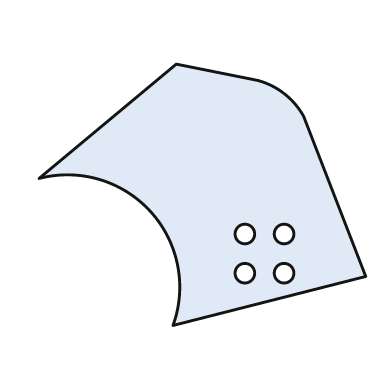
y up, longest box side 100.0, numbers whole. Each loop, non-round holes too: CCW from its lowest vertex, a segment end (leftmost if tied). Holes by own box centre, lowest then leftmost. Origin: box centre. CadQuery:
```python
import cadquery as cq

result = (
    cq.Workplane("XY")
    .moveTo(-9.0, -40.0)
    .lineTo(50.0, -25.0)
    .lineTo(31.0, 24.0)
    .threePointArc((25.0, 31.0), (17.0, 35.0))
    .lineTo(-8.0, 40.0)
    .lineTo(-50.0, 5.0)
    .threePointArc((-16.0, -5.0), (-9.0, -40.0))
    .close()
    .moveTo(13.0, -24.0)
    .circle(3.0)
    .moveTo(25.0, -24.0)
    .circle(3.0)
    .moveTo(13.0, -12.0)
    .circle(3.0)
    .moveTo(25.0, -12.0)
    .circle(3.0)
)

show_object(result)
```